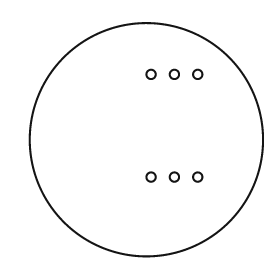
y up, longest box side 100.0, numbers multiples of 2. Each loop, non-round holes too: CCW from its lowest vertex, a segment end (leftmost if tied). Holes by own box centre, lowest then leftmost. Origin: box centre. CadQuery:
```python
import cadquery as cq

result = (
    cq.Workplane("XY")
    .moveTo(0.0, 0.0)
    .circle(50.0)
    .moveTo(2.0, -16.0)
    .circle(2.0)
    .moveTo(12.0, -16.0)
    .circle(2.0)
    .moveTo(22.0, -16.0)
    .circle(2.0)
    .moveTo(2.0, 28.0)
    .circle(2.0)
    .moveTo(12.0, 28.0)
    .circle(2.0)
    .moveTo(22.0, 28.0)
    .circle(2.0)
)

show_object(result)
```